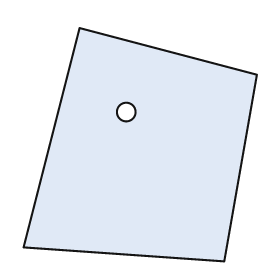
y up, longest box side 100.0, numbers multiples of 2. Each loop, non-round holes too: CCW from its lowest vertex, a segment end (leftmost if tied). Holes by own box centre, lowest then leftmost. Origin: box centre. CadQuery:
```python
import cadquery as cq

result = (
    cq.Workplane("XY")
    .moveTo(36.0, -50.0)
    .lineTo(50.0, 30.0)
    .lineTo(-26.0, 50.0)
    .lineTo(-50.0, -44.0)
    .close()
    .moveTo(-6.0, 14.0)
    .circle(4.0)
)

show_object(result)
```